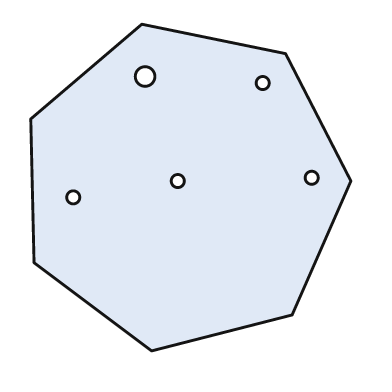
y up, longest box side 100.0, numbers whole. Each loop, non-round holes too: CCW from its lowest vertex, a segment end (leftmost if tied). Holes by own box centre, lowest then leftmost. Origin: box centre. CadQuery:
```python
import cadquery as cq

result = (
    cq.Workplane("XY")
    .moveTo(-12.0, -50.0)
    .lineTo(31.0, -39.0)
    .lineTo(49.0, 2.0)
    .lineTo(29.0, 41.0)
    .lineTo(-15.0, 50.0)
    .lineTo(-49.0, 21.0)
    .lineTo(-48.0, -23.0)
    .close()
    .moveTo(-36.0, -3.0)
    .circle(2.0)
    .moveTo(-4.0, 2.0)
    .circle(2.0)
    .moveTo(37.0, 3.0)
    .circle(2.0)
    .moveTo(22.0, 32.0)
    .circle(2.0)
    .moveTo(-14.0, 34.0)
    .circle(3.0)
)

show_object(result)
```